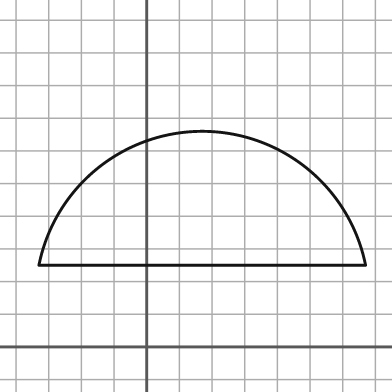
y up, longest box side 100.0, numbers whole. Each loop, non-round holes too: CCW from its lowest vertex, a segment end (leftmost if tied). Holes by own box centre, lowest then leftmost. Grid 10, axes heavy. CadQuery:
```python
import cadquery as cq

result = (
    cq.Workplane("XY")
    .moveTo(-33.0, 25.0)
    .lineTo(67.0, 25.0)
    .threePointArc((17.0, 66.0), (-33.0, 25.0))
    .close()
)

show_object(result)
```